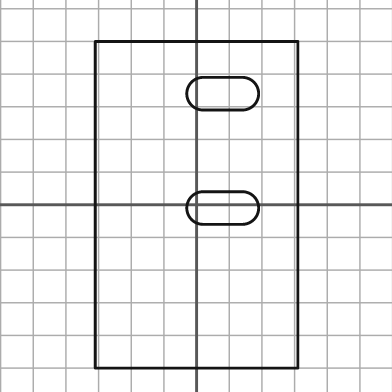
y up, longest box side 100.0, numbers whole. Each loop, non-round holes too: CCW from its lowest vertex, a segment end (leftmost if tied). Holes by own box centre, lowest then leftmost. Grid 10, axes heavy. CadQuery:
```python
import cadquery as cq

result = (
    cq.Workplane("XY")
    .moveTo(-31.0, -50.0)
    .lineTo(31.0, -50.0)
    .lineTo(31.0, 50.0)
    .lineTo(-31.0, 50.0)
    .close()
    .moveTo(2.0, -6.0)
    .lineTo(14.0, -6.0)
    .threePointArc((19.0, -1.0), (14.0, 4.0))
    .lineTo(2.0, 4.0)
    .threePointArc((-3.0, -1.0), (2.0, -6.0))
    .close()
    .moveTo(2.0, 29.0)
    .lineTo(14.0, 29.0)
    .threePointArc((19.0, 34.0), (14.0, 39.0))
    .lineTo(2.0, 39.0)
    .threePointArc((-3.0, 34.0), (2.0, 29.0))
    .close()
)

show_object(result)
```